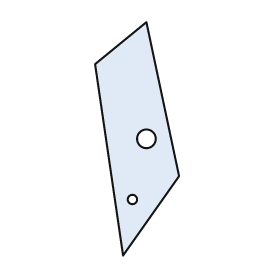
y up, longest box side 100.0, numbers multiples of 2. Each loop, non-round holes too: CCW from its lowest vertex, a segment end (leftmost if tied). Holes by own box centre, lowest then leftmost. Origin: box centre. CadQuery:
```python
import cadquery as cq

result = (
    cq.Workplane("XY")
    .moveTo(-6.0, -50.0)
    .lineTo(18.0, -16.0)
    .lineTo(4.0, 50.0)
    .lineTo(-18.0, 32.0)
    .close()
    .moveTo(-2.0, -26.0)
    .circle(2.0)
    .moveTo(4.0, 0.0)
    .circle(4.0)
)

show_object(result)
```